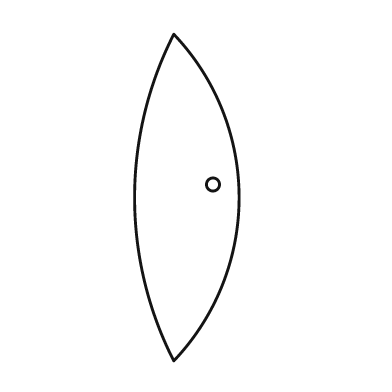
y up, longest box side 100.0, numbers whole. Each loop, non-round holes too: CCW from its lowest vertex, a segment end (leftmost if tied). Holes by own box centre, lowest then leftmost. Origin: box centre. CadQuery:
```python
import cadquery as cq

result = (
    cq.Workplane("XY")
    .moveTo(-4.0, -50.0)
    .threePointArc((16.0, 0.0), (-4.0, 50.0))
    .threePointArc((-16.0, 0.0), (-4.0, -50.0))
    .close()
    .moveTo(8.0, 4.0)
    .circle(2.0)
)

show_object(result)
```